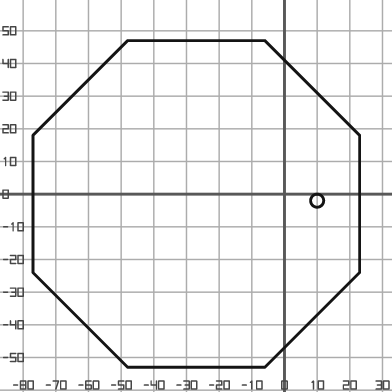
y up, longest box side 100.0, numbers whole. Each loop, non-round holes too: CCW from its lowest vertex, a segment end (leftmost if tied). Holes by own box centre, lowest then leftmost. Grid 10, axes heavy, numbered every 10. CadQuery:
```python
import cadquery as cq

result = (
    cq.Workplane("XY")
    .moveTo(-48.0, -53.0)
    .lineTo(-6.0, -53.0)
    .lineTo(23.0, -24.0)
    .lineTo(23.0, 18.0)
    .lineTo(-6.0, 47.0)
    .lineTo(-48.0, 47.0)
    .lineTo(-77.0, 18.0)
    .lineTo(-77.0, -24.0)
    .close()
    .moveTo(10.0, -2.0)
    .circle(2.0)
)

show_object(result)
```